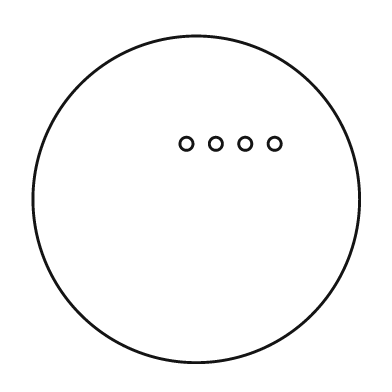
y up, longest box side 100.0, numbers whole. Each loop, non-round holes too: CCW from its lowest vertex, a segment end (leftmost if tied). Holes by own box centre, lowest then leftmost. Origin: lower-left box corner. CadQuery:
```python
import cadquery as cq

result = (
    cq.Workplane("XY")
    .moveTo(50.0, 50.0)
    .circle(50.0)
    .moveTo(47.0, 67.0)
    .circle(2.0)
    .moveTo(56.0, 67.0)
    .circle(2.0)
    .moveTo(65.0, 67.0)
    .circle(2.0)
    .moveTo(74.0, 67.0)
    .circle(2.0)
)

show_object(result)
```